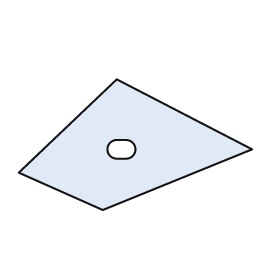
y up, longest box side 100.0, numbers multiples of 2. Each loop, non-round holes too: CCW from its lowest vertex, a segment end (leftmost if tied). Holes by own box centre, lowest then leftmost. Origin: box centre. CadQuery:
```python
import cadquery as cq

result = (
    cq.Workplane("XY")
    .moveTo(-14.0, -28.0)
    .lineTo(50.0, -2.0)
    .lineTo(-8.0, 28.0)
    .lineTo(-50.0, -12.0)
    .close()
    .moveTo(-8.0, -6.0)
    .lineTo(-4.0, -6.0)
    .threePointArc((0.0, -2.0), (-4.0, 2.0))
    .lineTo(-8.0, 2.0)
    .threePointArc((-12.0, -2.0), (-8.0, -6.0))
    .close()
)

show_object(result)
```